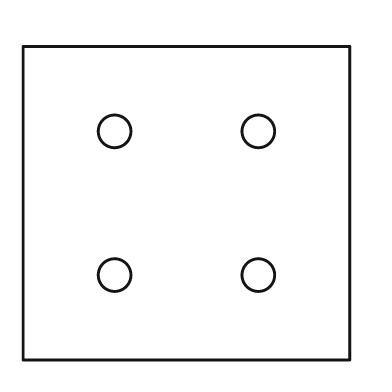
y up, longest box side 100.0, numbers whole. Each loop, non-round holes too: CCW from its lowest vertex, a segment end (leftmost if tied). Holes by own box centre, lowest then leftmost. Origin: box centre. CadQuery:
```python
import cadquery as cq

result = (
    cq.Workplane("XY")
    .moveTo(-50.0, -48.0)
    .lineTo(50.0, -48.0)
    .lineTo(50.0, 48.0)
    .lineTo(-50.0, 48.0)
    .close()
    .moveTo(-22.0, -22.0)
    .circle(5.0)
    .moveTo(22.0, -22.0)
    .circle(5.0)
    .moveTo(-22.0, 22.0)
    .circle(5.0)
    .moveTo(22.0, 22.0)
    .circle(5.0)
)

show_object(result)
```